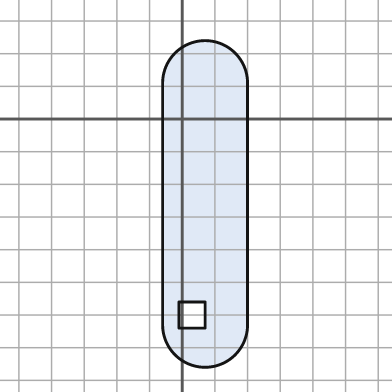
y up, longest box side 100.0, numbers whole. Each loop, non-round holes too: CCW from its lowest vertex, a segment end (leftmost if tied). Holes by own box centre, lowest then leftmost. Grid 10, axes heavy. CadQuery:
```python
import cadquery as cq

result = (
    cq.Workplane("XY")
    .moveTo(-6.0, -63.0)
    .threePointArc((7.0, -76.0), (20.0, -63.0))
    .lineTo(20.0, 11.0)
    .threePointArc((7.0, 24.0), (-6.0, 11.0))
    .close()
    .moveTo(-1.0, -64.0)
    .lineTo(7.0, -64.0)
    .lineTo(7.0, -56.0)
    .lineTo(-1.0, -56.0)
    .close()
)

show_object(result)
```